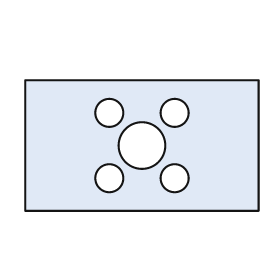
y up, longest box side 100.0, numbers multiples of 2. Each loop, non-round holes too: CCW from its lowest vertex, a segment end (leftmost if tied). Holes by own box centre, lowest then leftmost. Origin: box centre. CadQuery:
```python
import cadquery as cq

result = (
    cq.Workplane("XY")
    .moveTo(-50.0, -28.0)
    .lineTo(50.0, -28.0)
    .lineTo(50.0, 28.0)
    .lineTo(-50.0, 28.0)
    .close()
    .moveTo(-14.0, -14.0)
    .circle(6.0)
    .moveTo(14.0, -14.0)
    .circle(6.0)
    .moveTo(0.0, 0.0)
    .circle(10.0)
    .moveTo(-14.0, 14.0)
    .circle(6.0)
    .moveTo(14.0, 14.0)
    .circle(6.0)
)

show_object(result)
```